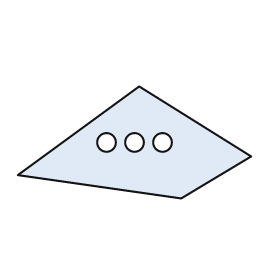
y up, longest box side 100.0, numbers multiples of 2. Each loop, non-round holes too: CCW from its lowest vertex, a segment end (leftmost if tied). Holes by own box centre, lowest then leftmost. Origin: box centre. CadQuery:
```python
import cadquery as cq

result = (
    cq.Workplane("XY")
    .moveTo(20.0, -24.0)
    .lineTo(50.0, -6.0)
    .lineTo(2.0, 24.0)
    .lineTo(-50.0, -14.0)
    .close()
    .moveTo(-12.0, 0.0)
    .circle(4.0)
    .moveTo(0.0, 0.0)
    .circle(4.0)
    .moveTo(12.0, 0.0)
    .circle(4.0)
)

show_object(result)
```